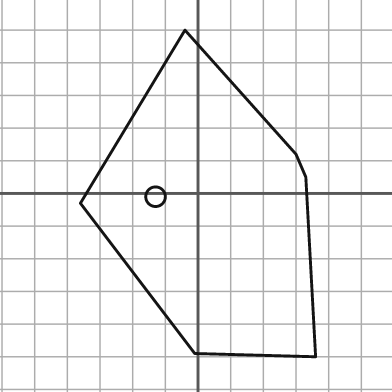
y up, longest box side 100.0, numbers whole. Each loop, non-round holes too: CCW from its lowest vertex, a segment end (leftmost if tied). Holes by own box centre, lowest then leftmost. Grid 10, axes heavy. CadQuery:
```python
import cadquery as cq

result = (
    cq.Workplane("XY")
    .moveTo(36.0, -50.0)
    .lineTo(33.0, 5.0)
    .lineTo(30.0, 12.0)
    .lineTo(-4.0, 50.0)
    .lineTo(-36.0, -3.0)
    .lineTo(-1.0, -49.0)
    .close()
    .moveTo(-13.0, -1.0)
    .circle(3.0)
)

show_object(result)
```